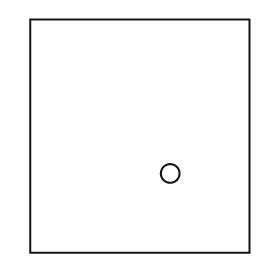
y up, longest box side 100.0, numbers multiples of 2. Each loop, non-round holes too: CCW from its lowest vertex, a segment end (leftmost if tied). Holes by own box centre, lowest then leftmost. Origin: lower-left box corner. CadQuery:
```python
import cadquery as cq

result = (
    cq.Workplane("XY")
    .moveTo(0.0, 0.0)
    .lineTo(94.0, 0.0)
    .lineTo(94.0, 100.0)
    .lineTo(0.0, 100.0)
    .close()
    .moveTo(60.0, 34.0)
    .circle(4.0)
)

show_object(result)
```